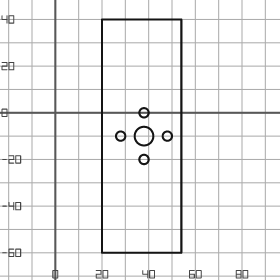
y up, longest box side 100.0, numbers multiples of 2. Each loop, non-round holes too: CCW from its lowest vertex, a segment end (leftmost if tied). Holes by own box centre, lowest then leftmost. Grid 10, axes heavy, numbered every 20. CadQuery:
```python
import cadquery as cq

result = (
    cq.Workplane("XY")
    .moveTo(20.0, -60.0)
    .lineTo(54.0, -60.0)
    .lineTo(54.0, 40.0)
    .lineTo(20.0, 40.0)
    .close()
    .moveTo(38.0, -20.0)
    .circle(2.0)
    .moveTo(28.0, -10.0)
    .circle(2.0)
    .moveTo(38.0, -10.0)
    .circle(4.0)
    .moveTo(48.0, -10.0)
    .circle(2.0)
    .moveTo(38.0, 0.0)
    .circle(2.0)
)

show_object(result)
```